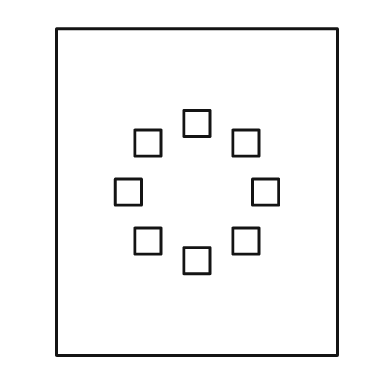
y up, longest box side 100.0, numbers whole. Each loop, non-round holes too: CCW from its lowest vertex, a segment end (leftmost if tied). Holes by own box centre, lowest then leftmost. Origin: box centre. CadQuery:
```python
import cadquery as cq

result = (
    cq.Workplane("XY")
    .moveTo(-43.0, -50.0)
    .lineTo(43.0, -50.0)
    .lineTo(43.0, 50.0)
    .lineTo(-43.0, 50.0)
    .close()
    .moveTo(-4.0, -25.0)
    .lineTo(4.0, -25.0)
    .lineTo(4.0, -17.0)
    .lineTo(-4.0, -17.0)
    .close()
    .moveTo(-19.0, -19.0)
    .lineTo(-11.0, -19.0)
    .lineTo(-11.0, -11.0)
    .lineTo(-19.0, -11.0)
    .close()
    .moveTo(11.0, -19.0)
    .lineTo(19.0, -19.0)
    .lineTo(19.0, -11.0)
    .lineTo(11.0, -11.0)
    .close()
    .moveTo(-25.0, -4.0)
    .lineTo(-17.0, -4.0)
    .lineTo(-17.0, 4.0)
    .lineTo(-25.0, 4.0)
    .close()
    .moveTo(17.0, -4.0)
    .lineTo(25.0, -4.0)
    .lineTo(25.0, 4.0)
    .lineTo(17.0, 4.0)
    .close()
    .moveTo(-19.0, 11.0)
    .lineTo(-11.0, 11.0)
    .lineTo(-11.0, 19.0)
    .lineTo(-19.0, 19.0)
    .close()
    .moveTo(11.0, 11.0)
    .lineTo(19.0, 11.0)
    .lineTo(19.0, 19.0)
    .lineTo(11.0, 19.0)
    .close()
    .moveTo(-4.0, 17.0)
    .lineTo(4.0, 17.0)
    .lineTo(4.0, 25.0)
    .lineTo(-4.0, 25.0)
    .close()
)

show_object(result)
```